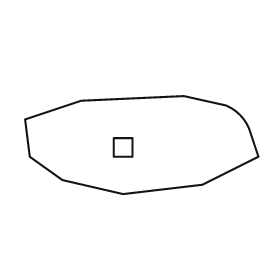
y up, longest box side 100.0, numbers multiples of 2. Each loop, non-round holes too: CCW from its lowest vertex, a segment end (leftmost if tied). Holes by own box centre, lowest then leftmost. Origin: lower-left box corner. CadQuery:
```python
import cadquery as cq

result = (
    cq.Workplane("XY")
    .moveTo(42.0, 0.0)
    .lineTo(76.0, 4.0)
    .lineTo(100.0, 16.0)
    .lineTo(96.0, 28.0)
    .threePointArc((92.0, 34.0), (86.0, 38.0))
    .lineTo(68.0, 42.0)
    .lineTo(24.0, 40.0)
    .lineTo(0.0, 32.0)
    .lineTo(2.0, 16.0)
    .lineTo(16.0, 6.0)
    .close()
    .moveTo(38.0, 16.0)
    .lineTo(46.0, 16.0)
    .lineTo(46.0, 24.0)
    .lineTo(38.0, 24.0)
    .close()
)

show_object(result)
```